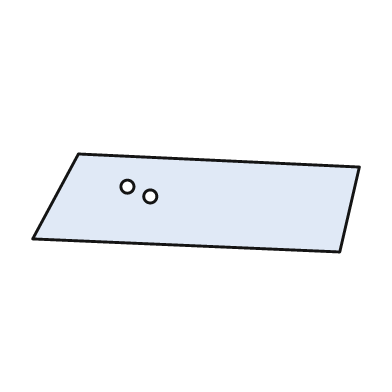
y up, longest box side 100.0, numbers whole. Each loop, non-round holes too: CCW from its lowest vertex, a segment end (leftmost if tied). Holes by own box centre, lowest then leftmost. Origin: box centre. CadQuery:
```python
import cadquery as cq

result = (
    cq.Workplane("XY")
    .moveTo(44.0, -15.0)
    .lineTo(50.0, 11.0)
    .lineTo(-36.0, 15.0)
    .lineTo(-50.0, -11.0)
    .close()
    .moveTo(-14.0, 2.0)
    .circle(2.0)
    .moveTo(-21.0, 5.0)
    .circle(2.0)
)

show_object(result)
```